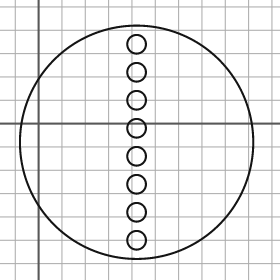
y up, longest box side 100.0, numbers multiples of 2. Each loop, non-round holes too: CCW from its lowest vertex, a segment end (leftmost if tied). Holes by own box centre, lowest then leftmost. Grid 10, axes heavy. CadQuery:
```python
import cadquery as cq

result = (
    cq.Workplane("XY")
    .moveTo(42.0, -8.0)
    .circle(50.0)
    .moveTo(42.0, -50.0)
    .circle(4.0)
    .moveTo(42.0, -38.0)
    .circle(4.0)
    .moveTo(42.0, -26.0)
    .circle(4.0)
    .moveTo(42.0, -14.0)
    .circle(4.0)
    .moveTo(42.0, -2.0)
    .circle(4.0)
    .moveTo(42.0, 10.0)
    .circle(4.0)
    .moveTo(42.0, 22.0)
    .circle(4.0)
    .moveTo(42.0, 34.0)
    .circle(4.0)
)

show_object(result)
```